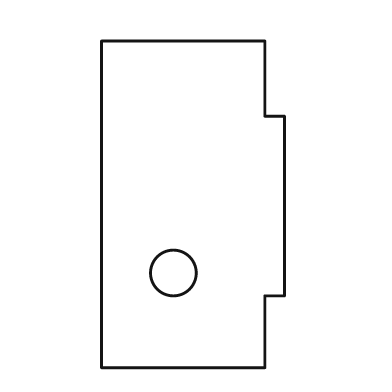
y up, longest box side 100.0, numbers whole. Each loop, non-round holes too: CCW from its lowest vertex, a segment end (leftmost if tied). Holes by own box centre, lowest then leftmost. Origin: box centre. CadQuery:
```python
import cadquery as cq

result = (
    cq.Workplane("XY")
    .moveTo(-28.0, -50.0)
    .lineTo(22.0, -50.0)
    .lineTo(22.0, -28.0)
    .lineTo(28.0, -28.0)
    .lineTo(28.0, 27.0)
    .lineTo(22.0, 27.0)
    .lineTo(22.0, 50.0)
    .lineTo(-28.0, 50.0)
    .close()
    .moveTo(-6.0, -21.0)
    .circle(7.0)
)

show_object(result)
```